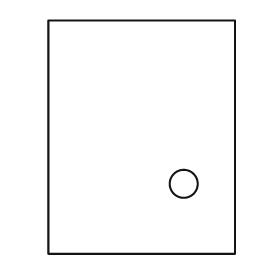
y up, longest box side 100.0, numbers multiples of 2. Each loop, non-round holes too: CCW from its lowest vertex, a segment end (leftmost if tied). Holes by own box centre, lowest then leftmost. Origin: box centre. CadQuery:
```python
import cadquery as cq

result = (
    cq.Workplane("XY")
    .moveTo(-40.0, -50.0)
    .lineTo(40.0, -50.0)
    .lineTo(40.0, 50.0)
    .lineTo(-40.0, 50.0)
    .close()
    .moveTo(18.0, -20.0)
    .circle(6.0)
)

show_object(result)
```